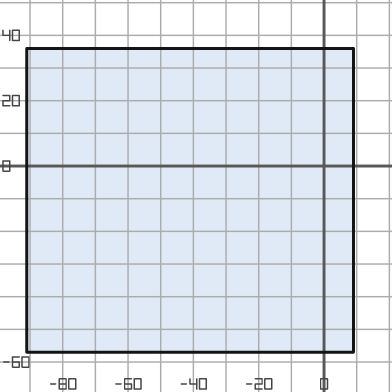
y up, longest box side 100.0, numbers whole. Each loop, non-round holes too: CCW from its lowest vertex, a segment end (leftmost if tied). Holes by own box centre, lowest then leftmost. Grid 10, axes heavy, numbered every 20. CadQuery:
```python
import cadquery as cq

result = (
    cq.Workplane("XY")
    .moveTo(-91.0, -57.0)
    .lineTo(9.0, -57.0)
    .lineTo(9.0, 36.0)
    .lineTo(-91.0, 36.0)
    .close()
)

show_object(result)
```